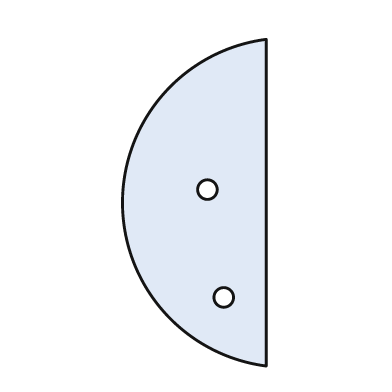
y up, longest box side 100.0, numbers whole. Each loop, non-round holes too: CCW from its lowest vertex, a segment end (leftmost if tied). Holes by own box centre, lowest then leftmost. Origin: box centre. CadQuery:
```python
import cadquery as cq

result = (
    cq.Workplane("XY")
    .moveTo(22.0, -50.0)
    .lineTo(22.0, 50.0)
    .threePointArc((-22.0, 0.0), (22.0, -50.0))
    .close()
    .moveTo(9.0, -29.0)
    .circle(3.0)
    .moveTo(4.0, 4.0)
    .circle(3.0)
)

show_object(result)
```